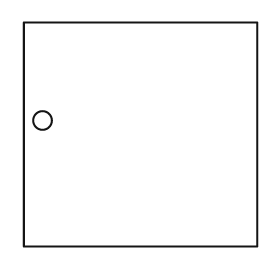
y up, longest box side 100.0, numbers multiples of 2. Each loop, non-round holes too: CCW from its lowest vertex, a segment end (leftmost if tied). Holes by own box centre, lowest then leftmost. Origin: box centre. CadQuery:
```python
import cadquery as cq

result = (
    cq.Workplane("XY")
    .moveTo(-50.0, -48.0)
    .lineTo(50.0, -48.0)
    .lineTo(50.0, 48.0)
    .lineTo(-50.0, 48.0)
    .close()
    .moveTo(-42.0, 6.0)
    .circle(4.0)
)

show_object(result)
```